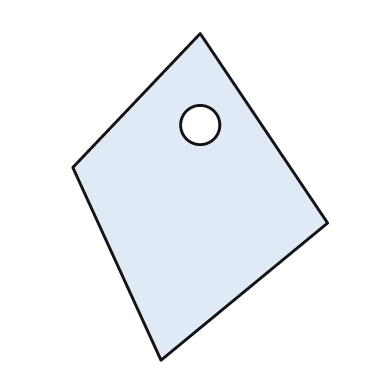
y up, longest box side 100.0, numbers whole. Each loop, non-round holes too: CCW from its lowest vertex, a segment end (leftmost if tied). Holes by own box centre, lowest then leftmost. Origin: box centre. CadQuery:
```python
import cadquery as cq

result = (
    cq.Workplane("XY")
    .moveTo(-12.0, -50.0)
    .lineTo(39.0, -8.0)
    .lineTo(0.0, 50.0)
    .lineTo(-39.0, 9.0)
    .close()
    .moveTo(0.0, 22.0)
    .circle(6.0)
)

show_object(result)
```